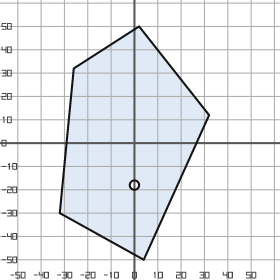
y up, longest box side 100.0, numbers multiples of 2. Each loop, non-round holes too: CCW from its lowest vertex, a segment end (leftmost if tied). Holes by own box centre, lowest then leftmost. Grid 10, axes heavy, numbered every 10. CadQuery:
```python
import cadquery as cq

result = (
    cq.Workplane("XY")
    .moveTo(4.0, -50.0)
    .lineTo(32.0, 12.0)
    .lineTo(2.0, 50.0)
    .lineTo(-26.0, 32.0)
    .lineTo(-32.0, -30.0)
    .close()
    .moveTo(0.0, -18.0)
    .circle(2.0)
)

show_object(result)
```